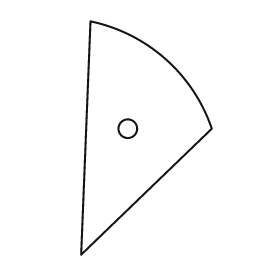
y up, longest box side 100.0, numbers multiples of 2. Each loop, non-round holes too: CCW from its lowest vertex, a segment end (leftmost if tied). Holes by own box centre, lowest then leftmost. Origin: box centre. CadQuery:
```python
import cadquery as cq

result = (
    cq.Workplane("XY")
    .moveTo(-28.0, -50.0)
    .lineTo(28.0, 4.0)
    .threePointArc((8.0, 34.0), (-24.0, 50.0))
    .close()
    .moveTo(-8.0, 4.0)
    .circle(4.0)
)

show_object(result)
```